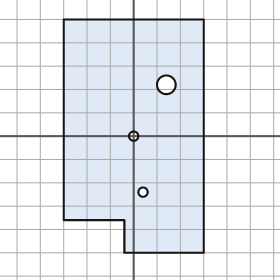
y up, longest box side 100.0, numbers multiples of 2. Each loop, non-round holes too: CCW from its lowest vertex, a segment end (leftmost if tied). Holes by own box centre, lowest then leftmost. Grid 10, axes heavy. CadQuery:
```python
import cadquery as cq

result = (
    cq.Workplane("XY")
    .moveTo(-4.0, -50.0)
    .lineTo(30.0, -50.0)
    .lineTo(30.0, 50.0)
    .lineTo(-30.0, 50.0)
    .lineTo(-30.0, -36.0)
    .lineTo(-4.0, -36.0)
    .close()
    .moveTo(4.0, -24.0)
    .circle(2.0)
    .moveTo(0.0, 0.0)
    .circle(2.0)
    .moveTo(14.0, 22.0)
    .circle(4.0)
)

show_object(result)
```